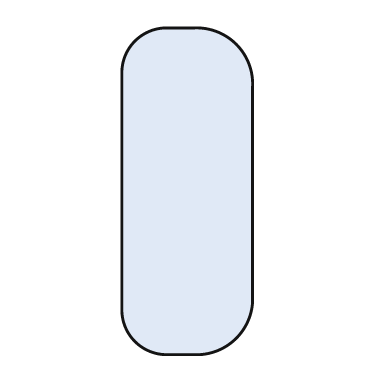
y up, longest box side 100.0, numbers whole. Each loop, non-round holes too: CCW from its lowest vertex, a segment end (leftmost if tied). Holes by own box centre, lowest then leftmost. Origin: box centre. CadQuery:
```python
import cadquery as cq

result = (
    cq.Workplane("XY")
    .moveTo(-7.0, -50.0)
    .lineTo(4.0, -50.0)
    .threePointArc((15.0, -45.0), (20.0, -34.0))
    .lineTo(20.0, 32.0)
    .threePointArc((15.0, 45.0), (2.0, 50.0))
    .lineTo(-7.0, 50.0)
    .threePointArc((-16.0, 46.0), (-20.0, 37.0))
    .lineTo(-20.0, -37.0)
    .threePointArc((-16.0, -46.0), (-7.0, -50.0))
    .close()
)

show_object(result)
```